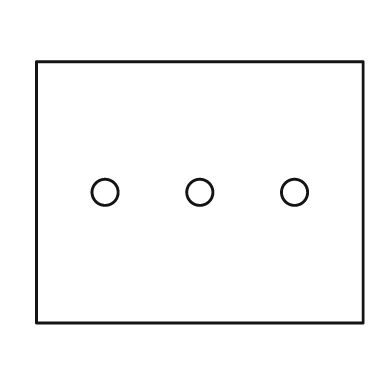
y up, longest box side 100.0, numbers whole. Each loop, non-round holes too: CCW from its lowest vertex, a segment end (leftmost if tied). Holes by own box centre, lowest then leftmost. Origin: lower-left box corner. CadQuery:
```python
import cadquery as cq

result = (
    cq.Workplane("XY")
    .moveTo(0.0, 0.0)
    .lineTo(100.0, 0.0)
    .lineTo(100.0, 80.0)
    .lineTo(0.0, 80.0)
    .close()
    .moveTo(21.0, 40.0)
    .circle(4.0)
    .moveTo(50.0, 40.0)
    .circle(4.0)
    .moveTo(79.0, 40.0)
    .circle(4.0)
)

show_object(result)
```